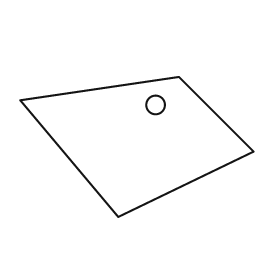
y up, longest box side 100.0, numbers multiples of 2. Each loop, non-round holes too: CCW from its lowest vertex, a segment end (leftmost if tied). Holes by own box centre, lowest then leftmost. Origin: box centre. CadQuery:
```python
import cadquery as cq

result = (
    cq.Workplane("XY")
    .moveTo(-8.0, -30.0)
    .lineTo(50.0, -2.0)
    .lineTo(18.0, 30.0)
    .lineTo(-50.0, 20.0)
    .close()
    .moveTo(8.0, 18.0)
    .circle(4.0)
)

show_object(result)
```